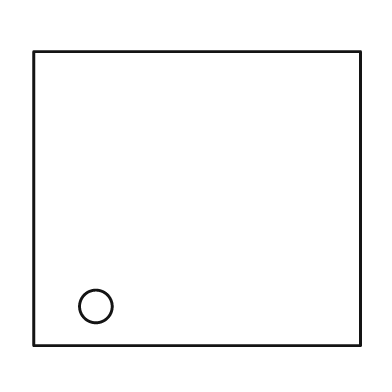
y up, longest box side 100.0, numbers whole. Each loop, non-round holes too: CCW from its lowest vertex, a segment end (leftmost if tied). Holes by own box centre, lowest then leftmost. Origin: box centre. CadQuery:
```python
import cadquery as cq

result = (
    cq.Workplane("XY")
    .moveTo(-50.0, -45.0)
    .lineTo(50.0, -45.0)
    .lineTo(50.0, 45.0)
    .lineTo(-50.0, 45.0)
    .close()
    .moveTo(-31.0, -33.0)
    .circle(5.0)
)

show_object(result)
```